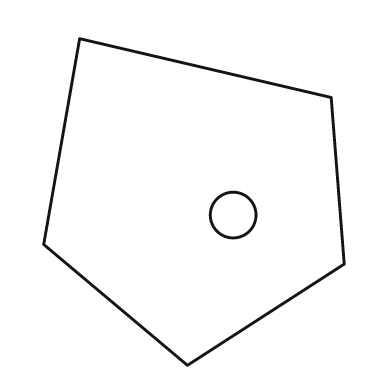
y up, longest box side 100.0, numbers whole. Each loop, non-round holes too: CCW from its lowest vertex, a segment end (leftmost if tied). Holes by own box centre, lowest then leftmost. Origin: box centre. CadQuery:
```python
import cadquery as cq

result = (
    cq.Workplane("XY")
    .moveTo(-2.0, -50.0)
    .lineTo(46.0, -19.0)
    .lineTo(42.0, 32.0)
    .lineTo(-35.0, 50.0)
    .lineTo(-46.0, -13.0)
    .close()
    .moveTo(12.0, -4.0)
    .circle(7.0)
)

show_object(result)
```